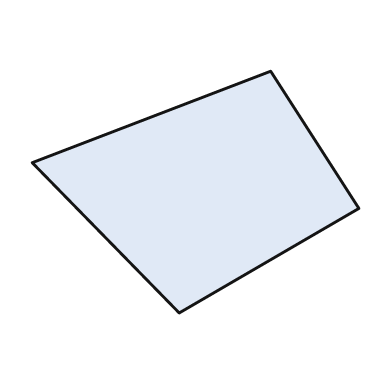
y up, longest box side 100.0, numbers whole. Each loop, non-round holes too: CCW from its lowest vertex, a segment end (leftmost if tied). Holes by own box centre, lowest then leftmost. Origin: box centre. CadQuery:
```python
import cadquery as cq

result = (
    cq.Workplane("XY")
    .moveTo(-5.0, -37.0)
    .lineTo(50.0, -5.0)
    .lineTo(23.0, 37.0)
    .lineTo(-50.0, 9.0)
    .close()
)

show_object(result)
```